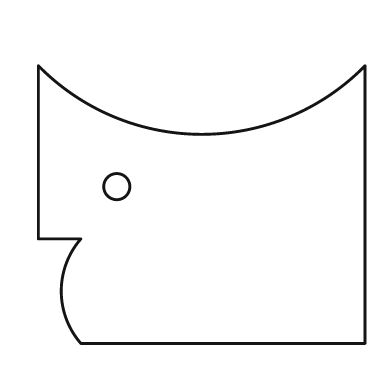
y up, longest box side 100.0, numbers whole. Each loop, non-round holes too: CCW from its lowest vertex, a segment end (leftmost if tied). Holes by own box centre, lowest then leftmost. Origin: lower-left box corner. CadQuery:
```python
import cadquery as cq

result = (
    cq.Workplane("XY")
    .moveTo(13.0, 0.0)
    .lineTo(100.0, 0.0)
    .lineTo(100.0, 85.0)
    .threePointArc((50.0, 64.0), (0.0, 85.0))
    .lineTo(0.0, 32.0)
    .lineTo(13.0, 32.0)
    .threePointArc((7.0, 16.0), (13.0, 0.0))
    .close()
    .moveTo(24.0, 48.0)
    .circle(4.0)
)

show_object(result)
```